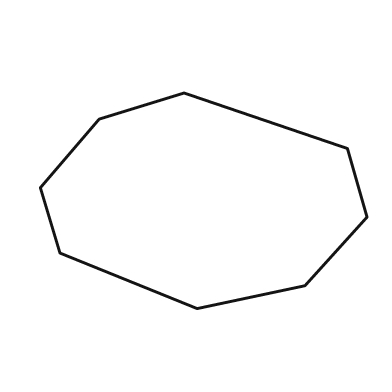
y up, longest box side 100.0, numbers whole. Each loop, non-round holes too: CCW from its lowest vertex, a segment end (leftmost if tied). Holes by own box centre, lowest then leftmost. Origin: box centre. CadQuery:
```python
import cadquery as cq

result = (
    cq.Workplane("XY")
    .moveTo(-2.0, -33.0)
    .lineTo(31.0, -26.0)
    .lineTo(50.0, -5.0)
    .lineTo(44.0, 16.0)
    .lineTo(-6.0, 33.0)
    .lineTo(-32.0, 25.0)
    .lineTo(-50.0, 4.0)
    .lineTo(-44.0, -16.0)
    .close()
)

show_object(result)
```